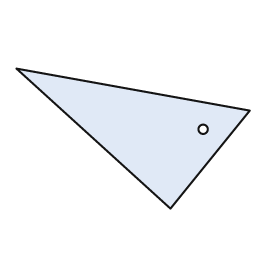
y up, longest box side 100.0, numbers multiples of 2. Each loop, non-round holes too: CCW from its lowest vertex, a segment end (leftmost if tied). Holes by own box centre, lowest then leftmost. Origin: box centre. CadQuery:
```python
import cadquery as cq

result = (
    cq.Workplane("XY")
    .moveTo(16.0, -30.0)
    .lineTo(50.0, 12.0)
    .lineTo(-50.0, 30.0)
    .close()
    .moveTo(30.0, 4.0)
    .circle(2.0)
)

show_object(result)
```